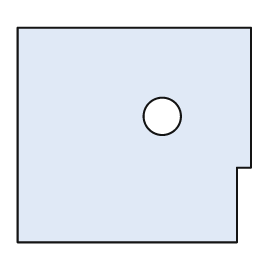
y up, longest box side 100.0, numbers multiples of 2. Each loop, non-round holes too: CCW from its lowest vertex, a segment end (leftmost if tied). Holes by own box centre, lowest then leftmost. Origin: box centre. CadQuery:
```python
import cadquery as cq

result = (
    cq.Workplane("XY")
    .moveTo(-50.0, -46.0)
    .lineTo(44.0, -46.0)
    .lineTo(44.0, -14.0)
    .lineTo(50.0, -14.0)
    .lineTo(50.0, 46.0)
    .lineTo(-50.0, 46.0)
    .close()
    .moveTo(12.0, 8.0)
    .circle(8.0)
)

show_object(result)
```